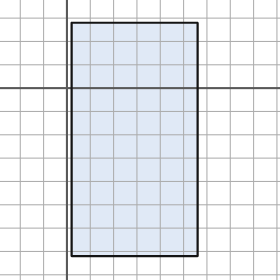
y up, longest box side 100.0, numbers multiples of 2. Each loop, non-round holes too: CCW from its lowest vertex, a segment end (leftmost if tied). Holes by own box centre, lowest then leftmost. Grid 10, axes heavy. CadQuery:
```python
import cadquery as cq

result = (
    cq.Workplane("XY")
    .moveTo(2.0, -72.0)
    .lineTo(56.0, -72.0)
    .lineTo(56.0, 28.0)
    .lineTo(2.0, 28.0)
    .close()
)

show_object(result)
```